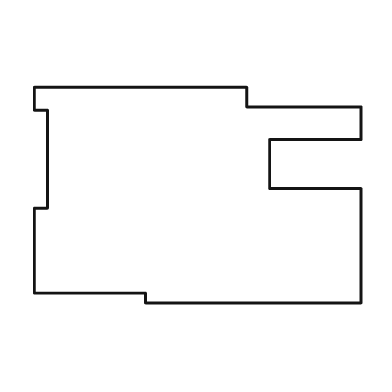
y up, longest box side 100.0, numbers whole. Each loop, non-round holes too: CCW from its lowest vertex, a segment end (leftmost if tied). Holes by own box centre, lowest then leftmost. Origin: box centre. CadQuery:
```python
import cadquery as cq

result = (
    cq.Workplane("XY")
    .moveTo(-16.0, -33.0)
    .lineTo(50.0, -33.0)
    .lineTo(50.0, 2.0)
    .lineTo(22.0, 2.0)
    .lineTo(22.0, 17.0)
    .lineTo(50.0, 17.0)
    .lineTo(50.0, 27.0)
    .lineTo(15.0, 27.0)
    .lineTo(15.0, 33.0)
    .lineTo(-50.0, 33.0)
    .lineTo(-50.0, 26.0)
    .lineTo(-46.0, 26.0)
    .lineTo(-46.0, -4.0)
    .lineTo(-50.0, -4.0)
    .lineTo(-50.0, -30.0)
    .lineTo(-16.0, -30.0)
    .close()
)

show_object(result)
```